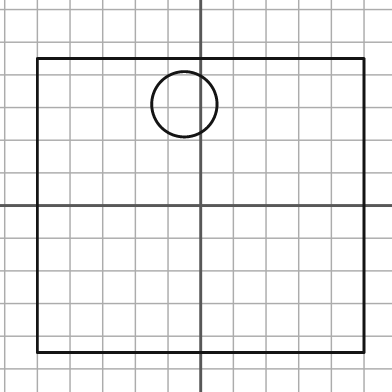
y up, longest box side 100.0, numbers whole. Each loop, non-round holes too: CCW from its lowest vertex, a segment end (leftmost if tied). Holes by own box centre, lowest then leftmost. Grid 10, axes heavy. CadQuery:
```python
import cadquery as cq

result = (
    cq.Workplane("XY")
    .moveTo(-50.0, -45.0)
    .lineTo(50.0, -45.0)
    .lineTo(50.0, 45.0)
    .lineTo(-50.0, 45.0)
    .close()
    .moveTo(-5.0, 31.0)
    .circle(10.0)
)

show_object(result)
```